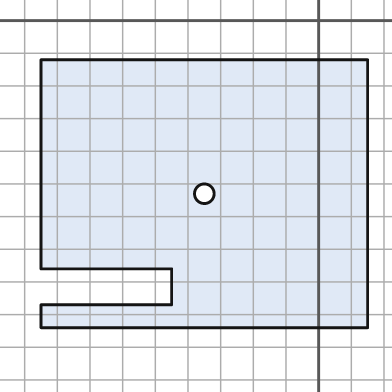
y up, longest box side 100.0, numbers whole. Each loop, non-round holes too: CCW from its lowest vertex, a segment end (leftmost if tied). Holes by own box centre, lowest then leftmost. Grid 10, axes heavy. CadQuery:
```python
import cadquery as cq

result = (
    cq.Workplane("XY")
    .moveTo(-85.0, -94.0)
    .lineTo(15.0, -94.0)
    .lineTo(15.0, -12.0)
    .lineTo(-85.0, -12.0)
    .lineTo(-85.0, -76.0)
    .lineTo(-45.0, -76.0)
    .lineTo(-45.0, -87.0)
    .lineTo(-85.0, -87.0)
    .close()
    .moveTo(-35.0, -53.0)
    .circle(3.0)
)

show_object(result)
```